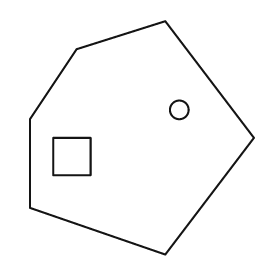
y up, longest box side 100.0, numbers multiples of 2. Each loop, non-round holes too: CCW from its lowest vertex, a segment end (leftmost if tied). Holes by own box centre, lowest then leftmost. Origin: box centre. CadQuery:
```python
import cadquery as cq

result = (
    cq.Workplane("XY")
    .moveTo(10.0, -50.0)
    .lineTo(48.0, 0.0)
    .lineTo(10.0, 50.0)
    .lineTo(-28.0, 38.0)
    .lineTo(-48.0, 8.0)
    .lineTo(-48.0, -30.0)
    .close()
    .moveTo(-38.0, -16.0)
    .lineTo(-22.0, -16.0)
    .lineTo(-22.0, 0.0)
    .lineTo(-38.0, 0.0)
    .close()
    .moveTo(16.0, 12.0)
    .circle(4.0)
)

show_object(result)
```